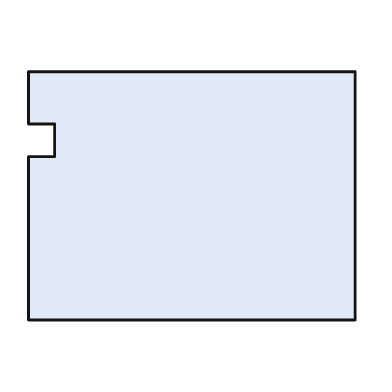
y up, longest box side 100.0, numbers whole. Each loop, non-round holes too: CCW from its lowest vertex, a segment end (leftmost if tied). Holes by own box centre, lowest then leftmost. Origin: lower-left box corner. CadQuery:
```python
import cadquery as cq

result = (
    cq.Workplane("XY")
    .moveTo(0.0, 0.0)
    .lineTo(100.0, 0.0)
    .lineTo(100.0, 76.0)
    .lineTo(0.0, 76.0)
    .lineTo(0.0, 60.0)
    .lineTo(8.0, 60.0)
    .lineTo(8.0, 50.0)
    .lineTo(0.0, 50.0)
    .close()
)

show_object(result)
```